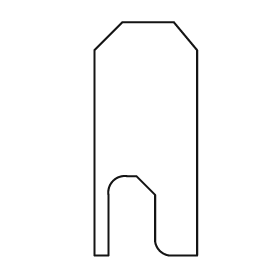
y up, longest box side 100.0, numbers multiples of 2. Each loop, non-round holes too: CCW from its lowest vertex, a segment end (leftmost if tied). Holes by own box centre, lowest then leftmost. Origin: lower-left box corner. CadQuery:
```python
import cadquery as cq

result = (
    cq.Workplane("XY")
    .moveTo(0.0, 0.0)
    .lineTo(6.0, 0.0)
    .lineTo(6.0, 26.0)
    .threePointArc((8.0, 32.0), (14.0, 34.0))
    .lineTo(18.0, 34.0)
    .lineTo(26.0, 26.0)
    .lineTo(26.0, 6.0)
    .threePointArc((28.0, 2.0), (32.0, 0.0))
    .lineTo(44.0, 0.0)
    .lineTo(44.0, 88.0)
    .lineTo(34.0, 100.0)
    .lineTo(12.0, 100.0)
    .lineTo(0.0, 88.0)
    .close()
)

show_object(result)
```